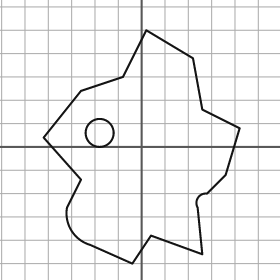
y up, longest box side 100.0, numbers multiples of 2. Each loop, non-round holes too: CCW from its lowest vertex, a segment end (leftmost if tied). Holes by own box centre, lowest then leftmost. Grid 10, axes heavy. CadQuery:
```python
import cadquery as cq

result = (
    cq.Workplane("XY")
    .moveTo(-4.0, -50.0)
    .lineTo(4.0, -38.0)
    .lineTo(26.0, -46.0)
    .lineTo(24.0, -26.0)
    .threePointArc((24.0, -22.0), (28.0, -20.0))
    .lineTo(36.0, -12.0)
    .lineTo(42.0, 8.0)
    .lineTo(26.0, 16.0)
    .lineTo(22.0, 38.0)
    .lineTo(2.0, 50.0)
    .lineTo(-8.0, 30.0)
    .lineTo(-26.0, 24.0)
    .lineTo(-42.0, 4.0)
    .lineTo(-26.0, -14.0)
    .lineTo(-32.0, -26.0)
    .threePointArc((-30.0, -36.0), (-22.0, -42.0))
    .close()
    .moveTo(-18.0, 6.0)
    .circle(6.0)
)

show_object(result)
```